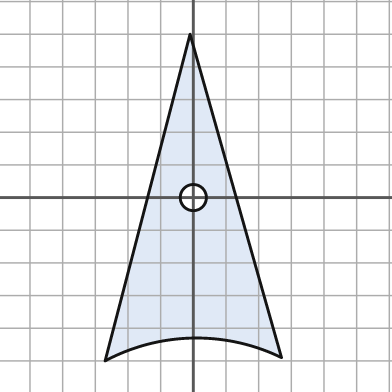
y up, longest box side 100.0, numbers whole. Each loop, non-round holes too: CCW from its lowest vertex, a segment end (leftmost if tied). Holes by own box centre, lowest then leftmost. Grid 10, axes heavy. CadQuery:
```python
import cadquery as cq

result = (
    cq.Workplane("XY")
    .moveTo(-27.0, -50.0)
    .threePointArc((0.0, -43.0), (27.0, -49.0))
    .lineTo(-1.0, 50.0)
    .close()
    .moveTo(0.0, 0.0)
    .circle(4.0)
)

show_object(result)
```